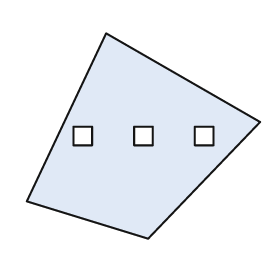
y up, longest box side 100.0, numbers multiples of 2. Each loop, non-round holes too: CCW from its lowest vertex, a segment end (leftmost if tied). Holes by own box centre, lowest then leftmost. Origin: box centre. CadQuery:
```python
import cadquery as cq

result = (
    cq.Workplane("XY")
    .moveTo(2.0, -44.0)
    .lineTo(50.0, 6.0)
    .lineTo(-16.0, 44.0)
    .lineTo(-50.0, -28.0)
    .close()
    .moveTo(-30.0, -4.0)
    .lineTo(-22.0, -4.0)
    .lineTo(-22.0, 4.0)
    .lineTo(-30.0, 4.0)
    .close()
    .moveTo(-4.0, -4.0)
    .lineTo(4.0, -4.0)
    .lineTo(4.0, 4.0)
    .lineTo(-4.0, 4.0)
    .close()
    .moveTo(22.0, -4.0)
    .lineTo(30.0, -4.0)
    .lineTo(30.0, 4.0)
    .lineTo(22.0, 4.0)
    .close()
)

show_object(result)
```